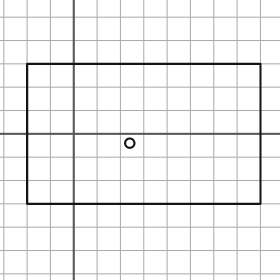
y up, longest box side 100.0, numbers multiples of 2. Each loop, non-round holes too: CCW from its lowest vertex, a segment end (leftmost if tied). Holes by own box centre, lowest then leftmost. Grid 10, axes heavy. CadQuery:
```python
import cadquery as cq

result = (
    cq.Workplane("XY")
    .moveTo(-20.0, -30.0)
    .lineTo(80.0, -30.0)
    .lineTo(80.0, 30.0)
    .lineTo(-20.0, 30.0)
    .close()
    .moveTo(24.0, -4.0)
    .circle(2.0)
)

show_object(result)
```